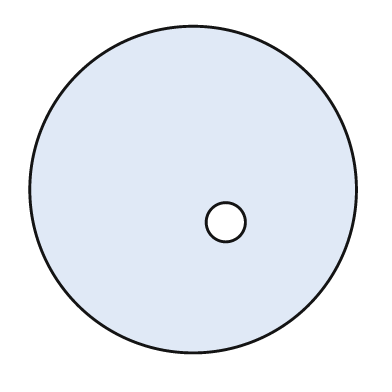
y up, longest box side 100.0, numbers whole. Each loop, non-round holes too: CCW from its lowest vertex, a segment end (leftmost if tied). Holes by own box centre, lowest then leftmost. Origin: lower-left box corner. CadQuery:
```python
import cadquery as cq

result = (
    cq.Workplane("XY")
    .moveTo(50.0, 50.0)
    .circle(50.0)
    .moveTo(60.0, 40.0)
    .circle(6.0)
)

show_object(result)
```